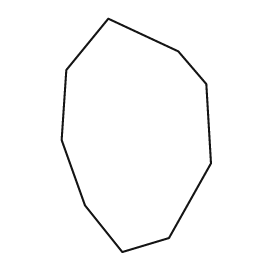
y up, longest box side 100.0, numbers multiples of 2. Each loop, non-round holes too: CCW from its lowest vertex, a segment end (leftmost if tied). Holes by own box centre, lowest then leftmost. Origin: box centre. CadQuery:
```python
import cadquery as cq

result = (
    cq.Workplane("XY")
    .moveTo(-6.0, -50.0)
    .lineTo(14.0, -44.0)
    .lineTo(32.0, -12.0)
    .lineTo(30.0, 22.0)
    .lineTo(18.0, 36.0)
    .lineTo(-12.0, 50.0)
    .lineTo(-30.0, 28.0)
    .lineTo(-32.0, -2.0)
    .lineTo(-22.0, -30.0)
    .close()
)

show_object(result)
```